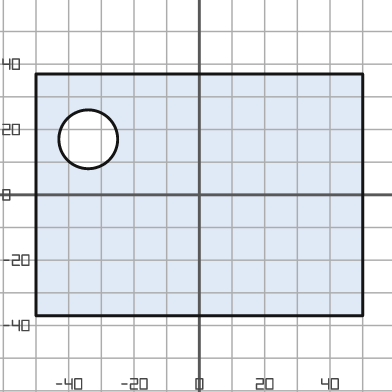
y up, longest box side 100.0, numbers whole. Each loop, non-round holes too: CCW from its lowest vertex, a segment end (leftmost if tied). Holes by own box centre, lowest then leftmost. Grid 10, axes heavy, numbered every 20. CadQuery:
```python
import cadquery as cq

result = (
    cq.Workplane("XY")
    .moveTo(-50.0, -37.0)
    .lineTo(50.0, -37.0)
    .lineTo(50.0, 37.0)
    .lineTo(-50.0, 37.0)
    .close()
    .moveTo(-34.0, 17.0)
    .circle(9.0)
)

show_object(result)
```